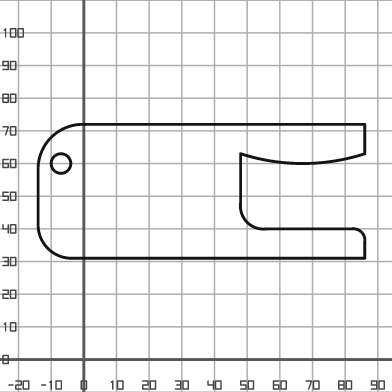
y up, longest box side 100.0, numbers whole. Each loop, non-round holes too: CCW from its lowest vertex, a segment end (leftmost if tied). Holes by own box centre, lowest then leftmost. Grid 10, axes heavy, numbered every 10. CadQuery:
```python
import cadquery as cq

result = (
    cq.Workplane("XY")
    .moveTo(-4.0, 31.0)
    .lineTo(86.0, 31.0)
    .lineTo(86.0, 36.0)
    .threePointArc((85.0, 39.0), (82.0, 40.0))
    .lineTo(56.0, 40.0)
    .threePointArc((50.0, 42.0), (48.0, 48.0))
    .lineTo(48.0, 63.0)
    .threePointArc((67.0, 60.0), (86.0, 63.0))
    .lineTo(86.0, 72.0)
    .lineTo(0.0, 72.0)
    .threePointArc((-10.0, 68.0), (-14.0, 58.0))
    .lineTo(-14.0, 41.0)
    .threePointArc((-11.0, 34.0), (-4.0, 31.0))
    .close()
    .moveTo(-7.0, 60.0)
    .circle(3.0)
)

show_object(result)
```